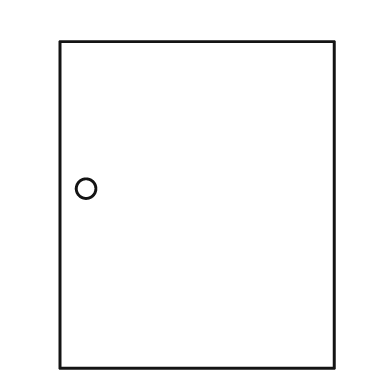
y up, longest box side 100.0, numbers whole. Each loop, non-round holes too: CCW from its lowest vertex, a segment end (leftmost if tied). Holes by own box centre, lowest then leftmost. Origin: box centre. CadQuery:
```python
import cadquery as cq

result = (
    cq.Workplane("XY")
    .moveTo(-42.0, -50.0)
    .lineTo(42.0, -50.0)
    .lineTo(42.0, 50.0)
    .lineTo(-42.0, 50.0)
    .close()
    .moveTo(-34.0, 5.0)
    .circle(3.0)
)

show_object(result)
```